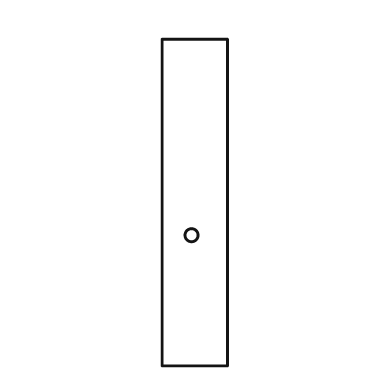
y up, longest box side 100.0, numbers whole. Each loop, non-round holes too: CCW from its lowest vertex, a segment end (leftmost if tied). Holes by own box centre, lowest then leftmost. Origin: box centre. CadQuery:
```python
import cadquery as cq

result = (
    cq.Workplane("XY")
    .moveTo(-10.0, -50.0)
    .lineTo(10.0, -50.0)
    .lineTo(10.0, 50.0)
    .lineTo(-10.0, 50.0)
    .close()
    .moveTo(-1.0, -10.0)
    .circle(2.0)
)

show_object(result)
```